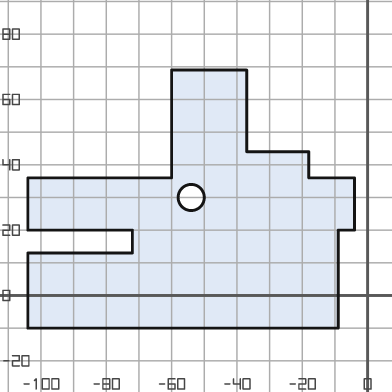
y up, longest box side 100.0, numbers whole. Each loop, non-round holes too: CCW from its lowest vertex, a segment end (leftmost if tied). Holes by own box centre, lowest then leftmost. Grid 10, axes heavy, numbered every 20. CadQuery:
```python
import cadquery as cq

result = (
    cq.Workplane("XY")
    .moveTo(-104.0, -10.0)
    .lineTo(-9.0, -10.0)
    .lineTo(-9.0, 20.0)
    .lineTo(-4.0, 20.0)
    .lineTo(-4.0, 36.0)
    .lineTo(-18.0, 36.0)
    .lineTo(-18.0, 44.0)
    .lineTo(-37.0, 44.0)
    .lineTo(-37.0, 69.0)
    .lineTo(-60.0, 69.0)
    .lineTo(-60.0, 36.0)
    .lineTo(-104.0, 36.0)
    .lineTo(-104.0, 20.0)
    .lineTo(-72.0, 20.0)
    .lineTo(-72.0, 13.0)
    .lineTo(-104.0, 13.0)
    .close()
    .moveTo(-54.0, 30.0)
    .circle(4.0)
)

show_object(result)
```